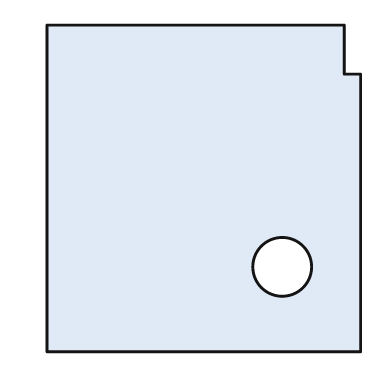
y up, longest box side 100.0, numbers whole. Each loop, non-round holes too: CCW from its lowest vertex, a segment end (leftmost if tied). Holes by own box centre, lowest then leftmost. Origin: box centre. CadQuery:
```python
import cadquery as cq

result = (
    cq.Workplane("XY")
    .moveTo(-48.0, -50.0)
    .lineTo(48.0, -50.0)
    .lineTo(48.0, 35.0)
    .lineTo(43.0, 35.0)
    .lineTo(43.0, 50.0)
    .lineTo(-48.0, 50.0)
    .close()
    .moveTo(24.0, -24.0)
    .circle(9.0)
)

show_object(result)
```